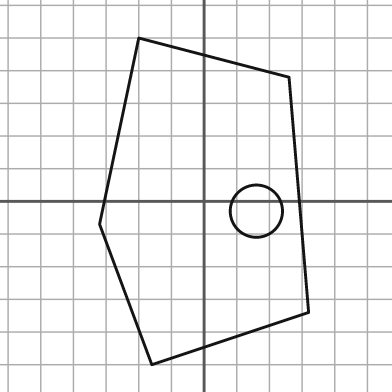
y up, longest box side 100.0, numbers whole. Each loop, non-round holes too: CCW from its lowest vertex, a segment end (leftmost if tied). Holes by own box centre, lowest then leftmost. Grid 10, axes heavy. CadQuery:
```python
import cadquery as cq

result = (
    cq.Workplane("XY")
    .moveTo(-16.0, -50.0)
    .lineTo(32.0, -34.0)
    .lineTo(26.0, 38.0)
    .lineTo(-20.0, 50.0)
    .lineTo(-32.0, -7.0)
    .close()
    .moveTo(16.0, -3.0)
    .circle(8.0)
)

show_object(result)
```